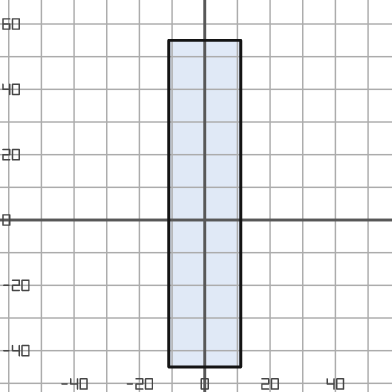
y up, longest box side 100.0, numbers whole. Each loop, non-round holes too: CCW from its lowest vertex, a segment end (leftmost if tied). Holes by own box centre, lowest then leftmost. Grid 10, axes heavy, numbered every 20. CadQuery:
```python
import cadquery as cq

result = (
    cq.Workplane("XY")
    .moveTo(-11.0, -45.0)
    .lineTo(11.0, -45.0)
    .lineTo(11.0, 55.0)
    .lineTo(-11.0, 55.0)
    .close()
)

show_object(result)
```